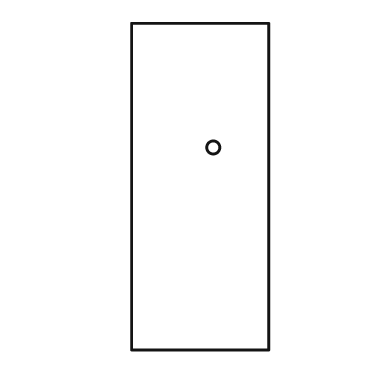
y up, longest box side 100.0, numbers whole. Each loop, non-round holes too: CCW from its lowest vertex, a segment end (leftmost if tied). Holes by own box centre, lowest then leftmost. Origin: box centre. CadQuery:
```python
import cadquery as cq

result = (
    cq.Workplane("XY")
    .moveTo(-21.0, -50.0)
    .lineTo(21.0, -50.0)
    .lineTo(21.0, 50.0)
    .lineTo(-21.0, 50.0)
    .close()
    .moveTo(4.0, 12.0)
    .circle(2.0)
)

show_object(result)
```